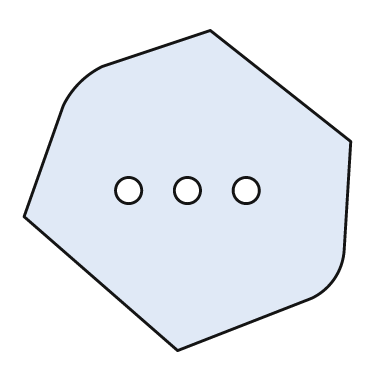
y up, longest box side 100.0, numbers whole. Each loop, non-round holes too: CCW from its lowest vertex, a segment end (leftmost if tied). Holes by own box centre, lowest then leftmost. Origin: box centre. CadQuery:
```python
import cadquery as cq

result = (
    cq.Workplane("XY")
    .moveTo(-3.0, -49.0)
    .lineTo(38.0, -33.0)
    .threePointArc((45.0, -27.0), (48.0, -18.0))
    .lineTo(50.0, 15.0)
    .lineTo(7.0, 49.0)
    .lineTo(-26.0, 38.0)
    .threePointArc((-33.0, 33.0), (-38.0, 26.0))
    .lineTo(-50.0, -8.0)
    .close()
    .moveTo(-18.0, 0.0)
    .circle(4.0)
    .moveTo(0.0, 0.0)
    .circle(4.0)
    .moveTo(18.0, 0.0)
    .circle(4.0)
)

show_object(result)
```